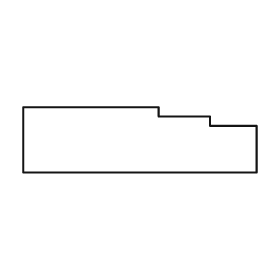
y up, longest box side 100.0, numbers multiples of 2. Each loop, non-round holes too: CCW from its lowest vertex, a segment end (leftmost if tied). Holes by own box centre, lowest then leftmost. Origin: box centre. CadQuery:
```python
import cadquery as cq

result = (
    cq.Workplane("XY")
    .moveTo(-50.0, -14.0)
    .lineTo(50.0, -14.0)
    .lineTo(50.0, 6.0)
    .lineTo(30.0, 6.0)
    .lineTo(30.0, 10.0)
    .lineTo(8.0, 10.0)
    .lineTo(8.0, 14.0)
    .lineTo(-50.0, 14.0)
    .close()
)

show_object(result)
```